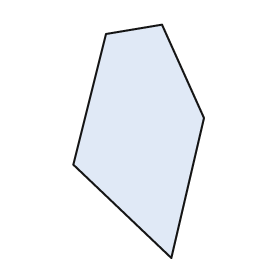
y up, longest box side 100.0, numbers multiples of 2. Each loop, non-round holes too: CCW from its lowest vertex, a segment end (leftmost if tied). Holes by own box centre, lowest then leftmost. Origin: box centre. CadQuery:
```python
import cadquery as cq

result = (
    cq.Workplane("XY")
    .moveTo(14.0, -50.0)
    .lineTo(28.0, 10.0)
    .lineTo(10.0, 50.0)
    .lineTo(-14.0, 46.0)
    .lineTo(-28.0, -10.0)
    .close()
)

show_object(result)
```